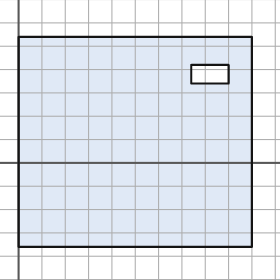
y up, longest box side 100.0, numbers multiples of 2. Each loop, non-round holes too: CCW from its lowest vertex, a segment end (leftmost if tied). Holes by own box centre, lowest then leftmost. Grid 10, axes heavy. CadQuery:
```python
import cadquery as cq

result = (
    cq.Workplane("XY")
    .moveTo(0.0, -36.0)
    .lineTo(100.0, -36.0)
    .lineTo(100.0, 54.0)
    .lineTo(0.0, 54.0)
    .close()
    .moveTo(74.0, 34.0)
    .lineTo(90.0, 34.0)
    .lineTo(90.0, 42.0)
    .lineTo(74.0, 42.0)
    .close()
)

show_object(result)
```